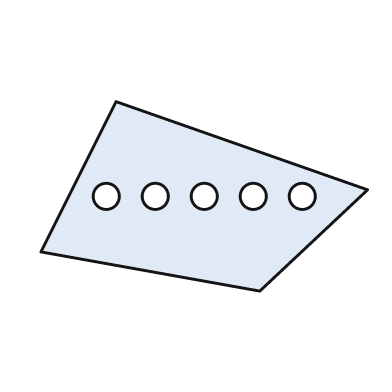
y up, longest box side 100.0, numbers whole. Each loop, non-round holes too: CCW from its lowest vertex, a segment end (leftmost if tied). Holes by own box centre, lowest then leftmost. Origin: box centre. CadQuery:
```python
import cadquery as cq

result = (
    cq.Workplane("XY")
    .moveTo(17.0, -29.0)
    .lineTo(50.0, 2.0)
    .lineTo(-27.0, 29.0)
    .lineTo(-50.0, -17.0)
    .close()
    .moveTo(-30.0, 0.0)
    .circle(4.0)
    .moveTo(-15.0, 0.0)
    .circle(4.0)
    .moveTo(0.0, 0.0)
    .circle(4.0)
    .moveTo(15.0, 0.0)
    .circle(4.0)
    .moveTo(30.0, 0.0)
    .circle(4.0)
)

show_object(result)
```